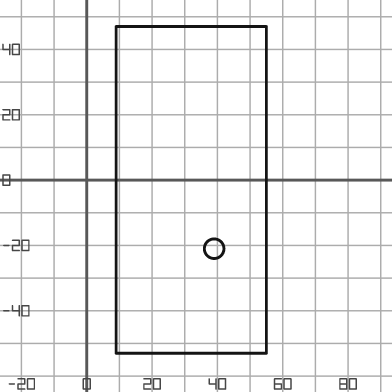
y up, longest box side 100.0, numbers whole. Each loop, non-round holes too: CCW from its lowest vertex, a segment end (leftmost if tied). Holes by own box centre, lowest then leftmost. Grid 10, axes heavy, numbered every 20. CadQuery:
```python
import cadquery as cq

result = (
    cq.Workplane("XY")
    .moveTo(9.0, -53.0)
    .lineTo(55.0, -53.0)
    .lineTo(55.0, 47.0)
    .lineTo(9.0, 47.0)
    .close()
    .moveTo(39.0, -21.0)
    .circle(3.0)
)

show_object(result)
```